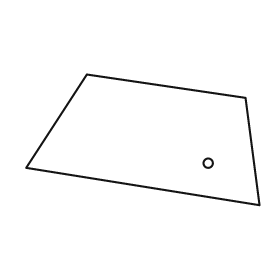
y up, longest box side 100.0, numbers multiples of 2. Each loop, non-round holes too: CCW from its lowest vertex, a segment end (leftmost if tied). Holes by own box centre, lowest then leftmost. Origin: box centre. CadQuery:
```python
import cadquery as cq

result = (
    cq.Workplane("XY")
    .moveTo(50.0, -28.0)
    .lineTo(44.0, 18.0)
    .lineTo(-24.0, 28.0)
    .lineTo(-50.0, -12.0)
    .close()
    .moveTo(28.0, -10.0)
    .circle(2.0)
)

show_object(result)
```